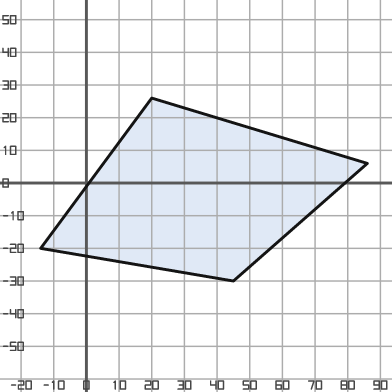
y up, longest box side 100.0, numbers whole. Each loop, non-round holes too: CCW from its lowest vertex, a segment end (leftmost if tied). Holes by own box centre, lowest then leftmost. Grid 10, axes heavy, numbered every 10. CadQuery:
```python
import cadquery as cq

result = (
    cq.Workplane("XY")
    .moveTo(45.0, -30.0)
    .lineTo(86.0, 6.0)
    .lineTo(20.0, 26.0)
    .lineTo(-14.0, -20.0)
    .close()
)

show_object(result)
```